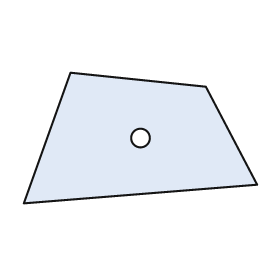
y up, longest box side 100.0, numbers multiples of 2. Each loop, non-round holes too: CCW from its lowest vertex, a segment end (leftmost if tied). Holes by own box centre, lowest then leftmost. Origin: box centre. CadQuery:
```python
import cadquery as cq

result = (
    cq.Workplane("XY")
    .moveTo(-50.0, -28.0)
    .lineTo(50.0, -20.0)
    .lineTo(28.0, 22.0)
    .lineTo(-30.0, 28.0)
    .close()
    .moveTo(0.0, 0.0)
    .circle(4.0)
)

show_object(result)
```